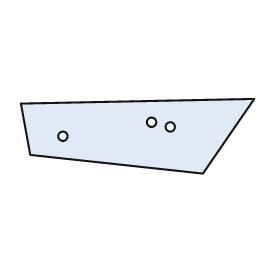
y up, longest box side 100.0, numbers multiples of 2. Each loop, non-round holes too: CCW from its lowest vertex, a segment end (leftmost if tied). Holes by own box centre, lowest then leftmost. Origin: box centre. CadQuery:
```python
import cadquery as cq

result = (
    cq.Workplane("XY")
    .moveTo(28.0, -16.0)
    .lineTo(50.0, 16.0)
    .lineTo(-50.0, 14.0)
    .lineTo(-46.0, -8.0)
    .close()
    .moveTo(-32.0, 0.0)
    .circle(2.0)
    .moveTo(14.0, 4.0)
    .circle(2.0)
    .moveTo(6.0, 6.0)
    .circle(2.0)
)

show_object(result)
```